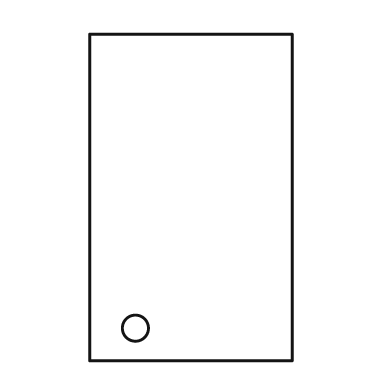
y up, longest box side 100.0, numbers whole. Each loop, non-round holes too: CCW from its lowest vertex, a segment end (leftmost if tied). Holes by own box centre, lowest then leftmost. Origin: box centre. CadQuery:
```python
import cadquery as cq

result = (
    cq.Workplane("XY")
    .moveTo(-31.0, -50.0)
    .lineTo(31.0, -50.0)
    .lineTo(31.0, 50.0)
    .lineTo(-31.0, 50.0)
    .close()
    .moveTo(-17.0, -40.0)
    .circle(4.0)
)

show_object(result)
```